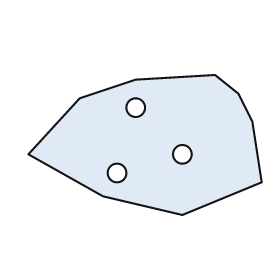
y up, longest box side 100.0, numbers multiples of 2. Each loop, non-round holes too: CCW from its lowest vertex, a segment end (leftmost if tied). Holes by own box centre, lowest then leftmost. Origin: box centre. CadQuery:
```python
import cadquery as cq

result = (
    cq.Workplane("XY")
    .moveTo(16.0, -30.0)
    .lineTo(50.0, -16.0)
    .lineTo(46.0, 10.0)
    .lineTo(40.0, 22.0)
    .lineTo(30.0, 30.0)
    .lineTo(-4.0, 28.0)
    .lineTo(-28.0, 20.0)
    .lineTo(-50.0, -4.0)
    .lineTo(-18.0, -22.0)
    .close()
    .moveTo(-12.0, -12.0)
    .circle(4.0)
    .moveTo(16.0, -4.0)
    .circle(4.0)
    .moveTo(-4.0, 16.0)
    .circle(4.0)
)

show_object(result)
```